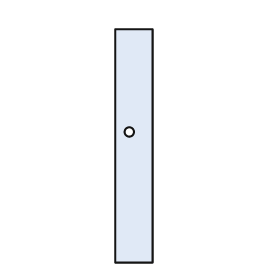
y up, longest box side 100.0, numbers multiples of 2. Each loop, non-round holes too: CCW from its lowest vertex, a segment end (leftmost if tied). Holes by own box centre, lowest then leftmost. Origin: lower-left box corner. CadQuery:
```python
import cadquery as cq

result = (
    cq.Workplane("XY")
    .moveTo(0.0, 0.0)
    .lineTo(16.0, 0.0)
    .lineTo(16.0, 100.0)
    .lineTo(0.0, 100.0)
    .close()
    .moveTo(6.0, 56.0)
    .circle(2.0)
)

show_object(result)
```